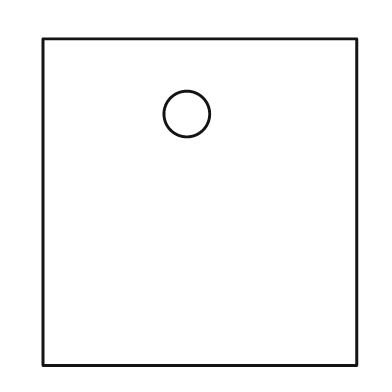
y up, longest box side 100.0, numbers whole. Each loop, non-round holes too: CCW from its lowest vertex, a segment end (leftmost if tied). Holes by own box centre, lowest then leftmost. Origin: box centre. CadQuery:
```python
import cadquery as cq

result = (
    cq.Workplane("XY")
    .moveTo(-48.0, -50.0)
    .lineTo(48.0, -50.0)
    .lineTo(48.0, 50.0)
    .lineTo(-48.0, 50.0)
    .close()
    .moveTo(-4.0, 27.0)
    .circle(7.0)
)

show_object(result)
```